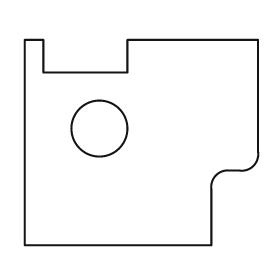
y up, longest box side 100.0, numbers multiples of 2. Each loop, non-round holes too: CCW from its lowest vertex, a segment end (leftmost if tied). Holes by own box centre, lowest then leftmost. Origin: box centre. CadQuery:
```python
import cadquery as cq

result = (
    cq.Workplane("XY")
    .moveTo(-50.0, -44.0)
    .lineTo(30.0, -44.0)
    .lineTo(30.0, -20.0)
    .threePointArc((32.0, -14.0), (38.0, -12.0))
    .lineTo(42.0, -12.0)
    .threePointArc((48.0, -10.0), (50.0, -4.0))
    .lineTo(50.0, 44.0)
    .lineTo(-6.0, 44.0)
    .lineTo(-6.0, 30.0)
    .lineTo(-42.0, 30.0)
    .lineTo(-42.0, 44.0)
    .lineTo(-50.0, 44.0)
    .close()
    .moveTo(-18.0, 6.0)
    .circle(12.0)
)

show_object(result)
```